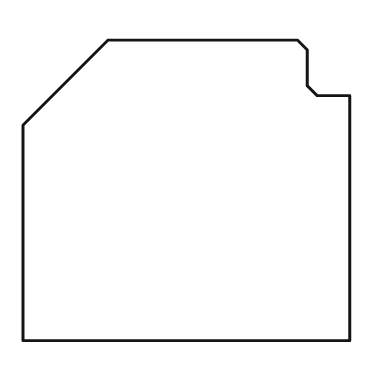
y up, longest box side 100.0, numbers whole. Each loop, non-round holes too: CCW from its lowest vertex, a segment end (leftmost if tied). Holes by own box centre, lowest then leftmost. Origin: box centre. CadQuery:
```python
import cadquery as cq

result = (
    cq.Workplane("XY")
    .moveTo(-50.0, -46.0)
    .lineTo(50.0, -46.0)
    .lineTo(50.0, 29.0)
    .lineTo(40.0, 29.0)
    .lineTo(37.0, 32.0)
    .lineTo(37.0, 43.0)
    .lineTo(34.0, 46.0)
    .lineTo(-24.0, 46.0)
    .lineTo(-50.0, 20.0)
    .close()
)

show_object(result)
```